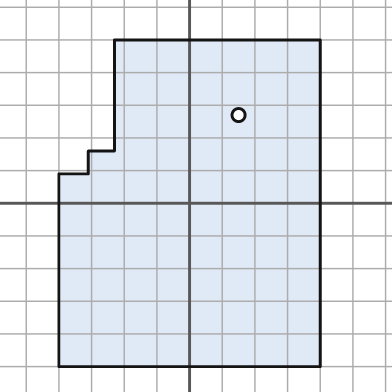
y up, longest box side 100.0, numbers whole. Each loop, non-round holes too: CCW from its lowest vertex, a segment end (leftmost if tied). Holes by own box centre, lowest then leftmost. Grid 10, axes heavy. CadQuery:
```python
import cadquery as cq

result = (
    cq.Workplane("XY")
    .moveTo(-40.0, -50.0)
    .lineTo(40.0, -50.0)
    .lineTo(40.0, 50.0)
    .lineTo(-23.0, 50.0)
    .lineTo(-23.0, 16.0)
    .lineTo(-31.0, 16.0)
    .lineTo(-31.0, 9.0)
    .lineTo(-40.0, 9.0)
    .close()
    .moveTo(15.0, 27.0)
    .circle(2.0)
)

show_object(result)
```